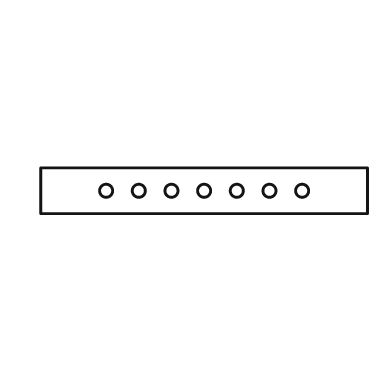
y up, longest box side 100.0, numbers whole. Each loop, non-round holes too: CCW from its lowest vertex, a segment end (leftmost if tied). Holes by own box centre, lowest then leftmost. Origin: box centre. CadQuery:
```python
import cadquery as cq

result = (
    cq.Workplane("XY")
    .moveTo(-50.0, -7.0)
    .lineTo(50.0, -7.0)
    .lineTo(50.0, 7.0)
    .lineTo(-50.0, 7.0)
    .close()
    .moveTo(-30.0, 0.0)
    .circle(2.0)
    .moveTo(-20.0, 0.0)
    .circle(2.0)
    .moveTo(-10.0, 0.0)
    .circle(2.0)
    .moveTo(0.0, 0.0)
    .circle(2.0)
    .moveTo(10.0, 0.0)
    .circle(2.0)
    .moveTo(20.0, 0.0)
    .circle(2.0)
    .moveTo(30.0, 0.0)
    .circle(2.0)
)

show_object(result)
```